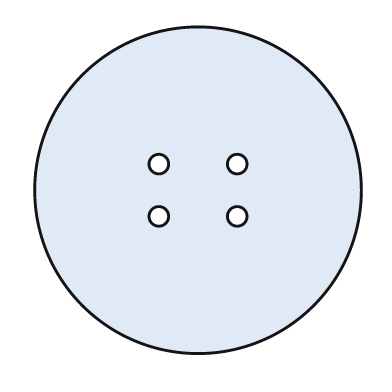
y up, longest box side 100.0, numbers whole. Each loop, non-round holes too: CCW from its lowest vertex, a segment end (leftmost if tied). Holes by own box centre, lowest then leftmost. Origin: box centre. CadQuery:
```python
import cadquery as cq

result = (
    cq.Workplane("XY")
    .moveTo(0.0, 0.0)
    .circle(50.0)
    .moveTo(-12.0, -8.0)
    .circle(3.0)
    .moveTo(12.0, -8.0)
    .circle(3.0)
    .moveTo(-12.0, 8.0)
    .circle(3.0)
    .moveTo(12.0, 8.0)
    .circle(3.0)
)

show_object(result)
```